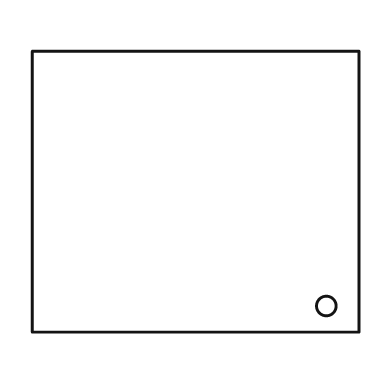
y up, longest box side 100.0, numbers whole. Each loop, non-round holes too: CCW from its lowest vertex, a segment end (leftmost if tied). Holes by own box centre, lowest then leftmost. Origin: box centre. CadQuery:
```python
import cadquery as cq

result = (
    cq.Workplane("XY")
    .moveTo(-50.0, -43.0)
    .lineTo(50.0, -43.0)
    .lineTo(50.0, 43.0)
    .lineTo(-50.0, 43.0)
    .close()
    .moveTo(40.0, -35.0)
    .circle(3.0)
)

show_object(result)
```